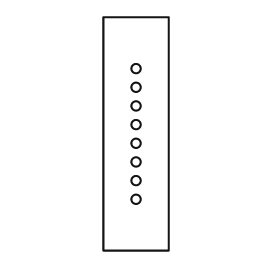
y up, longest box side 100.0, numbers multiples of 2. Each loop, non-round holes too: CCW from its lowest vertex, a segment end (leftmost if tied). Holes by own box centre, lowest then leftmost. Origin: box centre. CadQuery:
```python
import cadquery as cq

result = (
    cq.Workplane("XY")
    .moveTo(-14.0, -50.0)
    .lineTo(14.0, -50.0)
    .lineTo(14.0, 50.0)
    .lineTo(-14.0, 50.0)
    .close()
    .moveTo(0.0, -28.0)
    .circle(2.0)
    .moveTo(0.0, -20.0)
    .circle(2.0)
    .moveTo(0.0, -12.0)
    .circle(2.0)
    .moveTo(0.0, -4.0)
    .circle(2.0)
    .moveTo(0.0, 4.0)
    .circle(2.0)
    .moveTo(0.0, 12.0)
    .circle(2.0)
    .moveTo(0.0, 20.0)
    .circle(2.0)
    .moveTo(0.0, 28.0)
    .circle(2.0)
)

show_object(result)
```